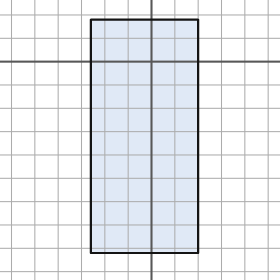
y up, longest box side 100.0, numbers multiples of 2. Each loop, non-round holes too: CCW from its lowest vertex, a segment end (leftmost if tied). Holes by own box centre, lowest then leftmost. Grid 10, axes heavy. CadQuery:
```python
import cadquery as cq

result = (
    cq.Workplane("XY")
    .moveTo(-26.0, -82.0)
    .lineTo(20.0, -82.0)
    .lineTo(20.0, 18.0)
    .lineTo(-26.0, 18.0)
    .close()
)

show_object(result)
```